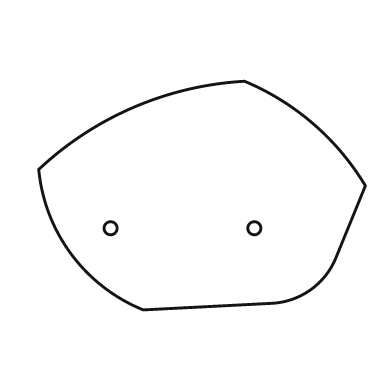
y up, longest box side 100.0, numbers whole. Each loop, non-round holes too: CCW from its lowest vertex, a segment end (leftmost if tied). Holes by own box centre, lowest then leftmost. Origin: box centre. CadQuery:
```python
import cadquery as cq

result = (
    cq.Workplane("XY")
    .moveTo(-18.0, -35.0)
    .lineTo(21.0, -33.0)
    .threePointArc((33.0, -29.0), (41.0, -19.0))
    .lineTo(50.0, 3.0)
    .threePointArc((34.0, 22.0), (13.0, 35.0))
    .threePointArc((-21.0, 27.0), (-50.0, 8.0))
    .threePointArc((-40.0, -18.0), (-18.0, -35.0))
    .close()
    .moveTo(-28.0, -10.0)
    .circle(2.0)
    .moveTo(16.0, -10.0)
    .circle(2.0)
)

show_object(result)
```